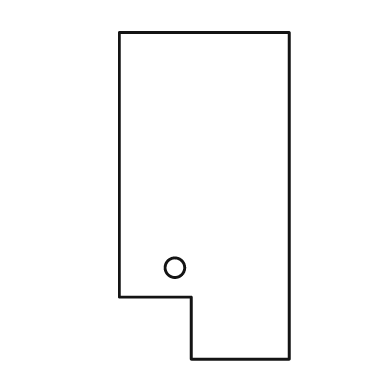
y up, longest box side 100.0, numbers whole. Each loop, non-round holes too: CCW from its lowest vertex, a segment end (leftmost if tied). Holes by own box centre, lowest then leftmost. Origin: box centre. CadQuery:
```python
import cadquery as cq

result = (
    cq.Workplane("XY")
    .moveTo(-4.0, -50.0)
    .lineTo(26.0, -50.0)
    .lineTo(26.0, 50.0)
    .lineTo(-26.0, 50.0)
    .lineTo(-26.0, -31.0)
    .lineTo(-4.0, -31.0)
    .close()
    .moveTo(-9.0, -22.0)
    .circle(3.0)
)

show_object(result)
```